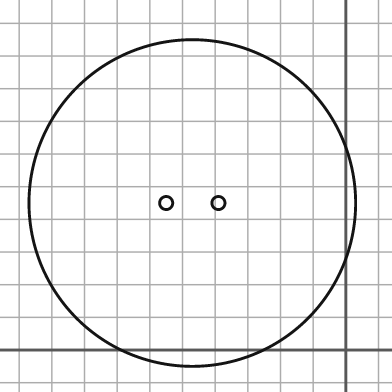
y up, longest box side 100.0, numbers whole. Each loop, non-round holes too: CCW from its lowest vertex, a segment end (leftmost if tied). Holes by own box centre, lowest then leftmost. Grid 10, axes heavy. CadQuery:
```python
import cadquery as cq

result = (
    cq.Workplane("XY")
    .moveTo(-47.0, 45.0)
    .circle(50.0)
    .moveTo(-55.0, 45.0)
    .circle(2.0)
    .moveTo(-39.0, 45.0)
    .circle(2.0)
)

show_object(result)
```